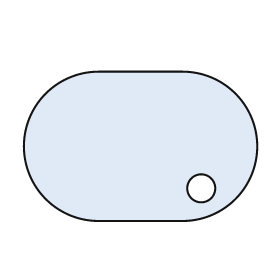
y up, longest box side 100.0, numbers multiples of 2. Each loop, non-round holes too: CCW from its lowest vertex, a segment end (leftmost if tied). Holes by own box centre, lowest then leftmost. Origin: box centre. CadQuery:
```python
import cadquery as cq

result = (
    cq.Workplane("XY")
    .moveTo(-18.0, -32.0)
    .lineTo(18.0, -32.0)
    .threePointArc((50.0, 0.0), (18.0, 32.0))
    .lineTo(-18.0, 32.0)
    .threePointArc((-50.0, 0.0), (-18.0, -32.0))
    .close()
    .moveTo(26.0, -18.0)
    .circle(6.0)
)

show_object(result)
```